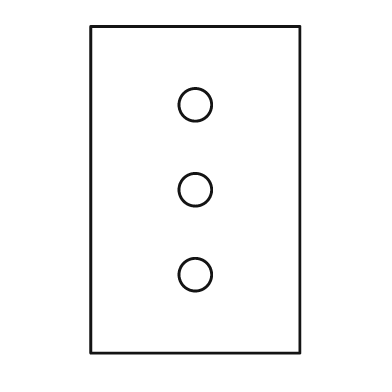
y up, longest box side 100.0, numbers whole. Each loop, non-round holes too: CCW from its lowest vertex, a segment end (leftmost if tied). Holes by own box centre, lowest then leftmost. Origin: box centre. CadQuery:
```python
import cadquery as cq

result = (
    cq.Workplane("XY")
    .moveTo(-32.0, -50.0)
    .lineTo(32.0, -50.0)
    .lineTo(32.0, 50.0)
    .lineTo(-32.0, 50.0)
    .close()
    .moveTo(0.0, -26.0)
    .circle(5.0)
    .moveTo(0.0, 0.0)
    .circle(5.0)
    .moveTo(0.0, 26.0)
    .circle(5.0)
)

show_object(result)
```